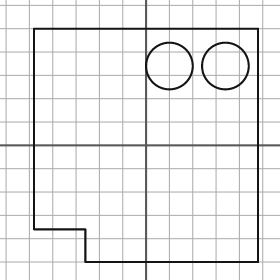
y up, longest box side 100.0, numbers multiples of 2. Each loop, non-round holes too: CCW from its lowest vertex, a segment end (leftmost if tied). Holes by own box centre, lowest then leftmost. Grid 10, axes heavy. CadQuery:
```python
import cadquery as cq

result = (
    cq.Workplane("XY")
    .moveTo(-26.0, -50.0)
    .lineTo(48.0, -50.0)
    .lineTo(48.0, 50.0)
    .lineTo(-48.0, 50.0)
    .lineTo(-48.0, -36.0)
    .lineTo(-26.0, -36.0)
    .close()
    .moveTo(10.0, 34.0)
    .circle(10.0)
    .moveTo(34.0, 34.0)
    .circle(10.0)
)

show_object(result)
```